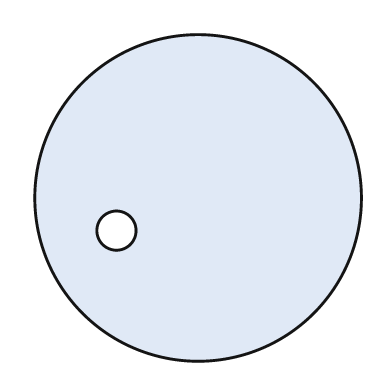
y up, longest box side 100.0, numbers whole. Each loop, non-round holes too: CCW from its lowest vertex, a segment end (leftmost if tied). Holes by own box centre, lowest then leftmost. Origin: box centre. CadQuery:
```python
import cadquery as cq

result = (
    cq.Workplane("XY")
    .moveTo(0.0, 0.0)
    .circle(50.0)
    .moveTo(-25.0, -10.0)
    .circle(6.0)
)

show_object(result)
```